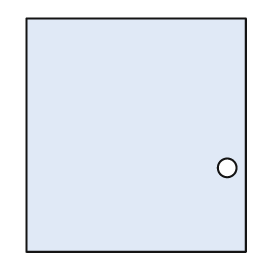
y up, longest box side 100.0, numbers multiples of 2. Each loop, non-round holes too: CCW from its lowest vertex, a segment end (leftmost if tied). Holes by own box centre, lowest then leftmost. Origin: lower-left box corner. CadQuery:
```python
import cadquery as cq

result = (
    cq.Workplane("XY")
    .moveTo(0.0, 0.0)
    .lineTo(94.0, 0.0)
    .lineTo(94.0, 100.0)
    .lineTo(0.0, 100.0)
    .close()
    .moveTo(86.0, 36.0)
    .circle(4.0)
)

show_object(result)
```